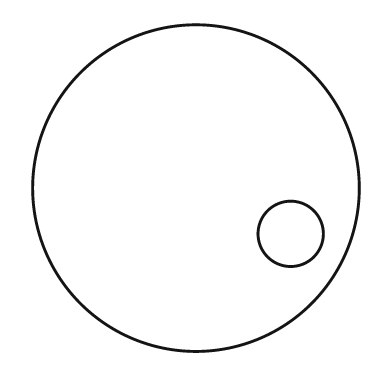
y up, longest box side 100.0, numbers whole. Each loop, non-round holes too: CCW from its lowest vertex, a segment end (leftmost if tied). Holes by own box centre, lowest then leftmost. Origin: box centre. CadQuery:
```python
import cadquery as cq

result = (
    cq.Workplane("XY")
    .moveTo(0.0, 0.0)
    .circle(50.0)
    .moveTo(29.0, -14.0)
    .circle(10.0)
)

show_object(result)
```